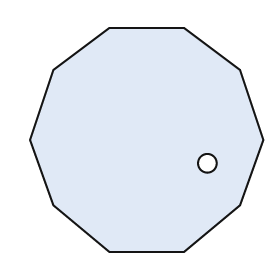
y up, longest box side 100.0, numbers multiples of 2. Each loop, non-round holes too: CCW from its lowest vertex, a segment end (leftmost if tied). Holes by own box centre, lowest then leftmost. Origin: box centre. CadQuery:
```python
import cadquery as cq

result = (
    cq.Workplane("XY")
    .moveTo(-16.0, -48.0)
    .lineTo(16.0, -48.0)
    .lineTo(40.0, -28.0)
    .lineTo(50.0, 0.0)
    .lineTo(40.0, 30.0)
    .lineTo(16.0, 48.0)
    .lineTo(-16.0, 48.0)
    .lineTo(-40.0, 30.0)
    .lineTo(-50.0, 0.0)
    .lineTo(-40.0, -28.0)
    .close()
    .moveTo(26.0, -10.0)
    .circle(4.0)
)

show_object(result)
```